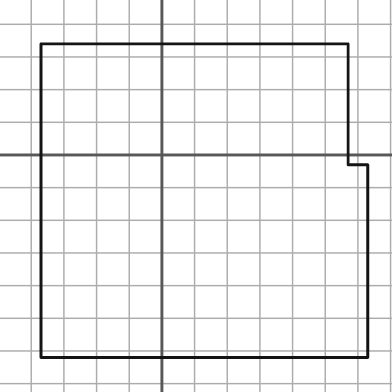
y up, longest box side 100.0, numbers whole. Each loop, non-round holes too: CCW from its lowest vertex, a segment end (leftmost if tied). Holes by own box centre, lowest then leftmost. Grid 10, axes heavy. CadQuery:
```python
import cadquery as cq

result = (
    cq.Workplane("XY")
    .moveTo(-37.0, -62.0)
    .lineTo(63.0, -62.0)
    .lineTo(63.0, -3.0)
    .lineTo(57.0, -3.0)
    .lineTo(57.0, 34.0)
    .lineTo(-37.0, 34.0)
    .close()
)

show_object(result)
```